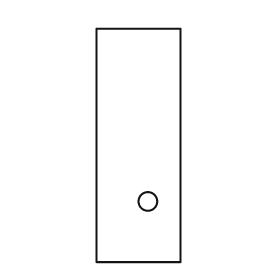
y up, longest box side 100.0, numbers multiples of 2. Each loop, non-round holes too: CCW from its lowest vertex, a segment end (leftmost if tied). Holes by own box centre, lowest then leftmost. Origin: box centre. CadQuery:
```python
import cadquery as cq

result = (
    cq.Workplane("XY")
    .moveTo(-18.0, -50.0)
    .lineTo(18.0, -50.0)
    .lineTo(18.0, 50.0)
    .lineTo(-18.0, 50.0)
    .close()
    .moveTo(4.0, -24.0)
    .circle(4.0)
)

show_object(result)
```